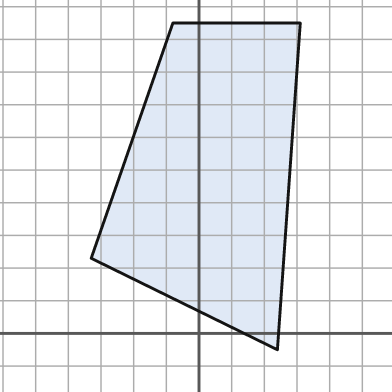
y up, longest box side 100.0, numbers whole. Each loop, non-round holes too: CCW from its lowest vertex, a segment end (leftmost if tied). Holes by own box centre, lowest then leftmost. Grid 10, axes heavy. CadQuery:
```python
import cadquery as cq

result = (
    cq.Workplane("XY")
    .moveTo(24.0, -5.0)
    .lineTo(31.0, 95.0)
    .lineTo(-8.0, 95.0)
    .lineTo(-33.0, 23.0)
    .close()
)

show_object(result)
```